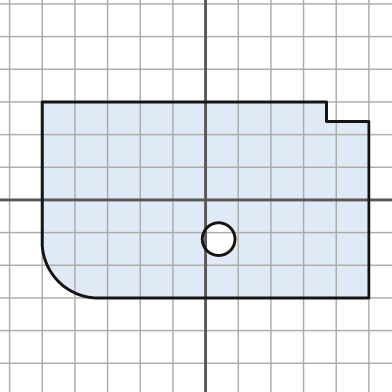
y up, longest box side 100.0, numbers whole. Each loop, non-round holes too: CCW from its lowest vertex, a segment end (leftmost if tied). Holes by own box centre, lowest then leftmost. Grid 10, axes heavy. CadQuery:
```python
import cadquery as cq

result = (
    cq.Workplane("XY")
    .moveTo(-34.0, -30.0)
    .lineTo(50.0, -30.0)
    .lineTo(50.0, 24.0)
    .lineTo(37.0, 24.0)
    .lineTo(37.0, 30.0)
    .lineTo(-50.0, 30.0)
    .lineTo(-50.0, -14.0)
    .threePointArc((-45.0, -25.0), (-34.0, -30.0))
    .close()
    .moveTo(4.0, -12.0)
    .circle(5.0)
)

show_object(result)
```